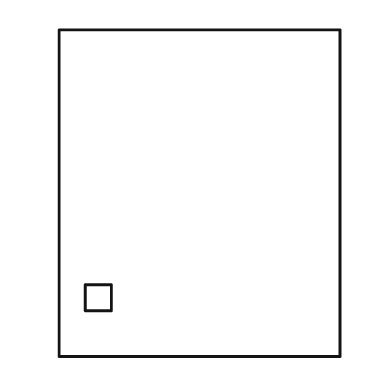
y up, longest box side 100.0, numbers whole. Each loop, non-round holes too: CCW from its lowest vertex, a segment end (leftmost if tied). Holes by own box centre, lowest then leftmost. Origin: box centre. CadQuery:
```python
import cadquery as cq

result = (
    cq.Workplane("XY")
    .moveTo(-43.0, -50.0)
    .lineTo(43.0, -50.0)
    .lineTo(43.0, 50.0)
    .lineTo(-43.0, 50.0)
    .close()
    .moveTo(-35.0, -36.0)
    .lineTo(-27.0, -36.0)
    .lineTo(-27.0, -28.0)
    .lineTo(-35.0, -28.0)
    .close()
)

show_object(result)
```